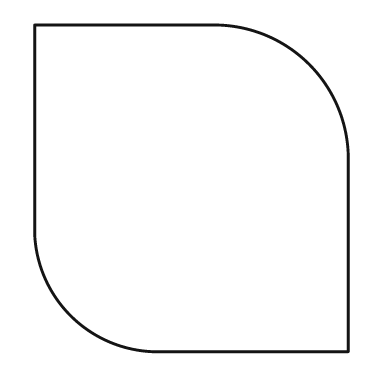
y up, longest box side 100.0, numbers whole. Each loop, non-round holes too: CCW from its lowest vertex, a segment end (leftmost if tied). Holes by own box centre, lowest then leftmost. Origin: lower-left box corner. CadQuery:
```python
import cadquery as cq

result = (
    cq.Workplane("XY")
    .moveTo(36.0, 0.0)
    .lineTo(96.0, 0.0)
    .lineTo(96.0, 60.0)
    .threePointArc((84.0, 88.0), (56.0, 100.0))
    .lineTo(0.0, 100.0)
    .lineTo(0.0, 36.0)
    .threePointArc((11.0, 11.0), (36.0, 0.0))
    .close()
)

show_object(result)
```